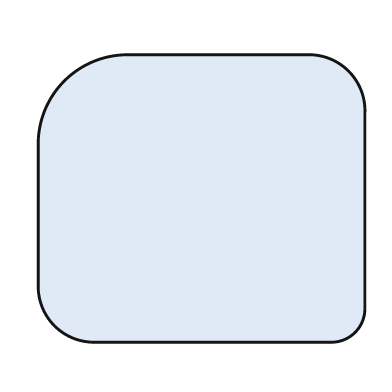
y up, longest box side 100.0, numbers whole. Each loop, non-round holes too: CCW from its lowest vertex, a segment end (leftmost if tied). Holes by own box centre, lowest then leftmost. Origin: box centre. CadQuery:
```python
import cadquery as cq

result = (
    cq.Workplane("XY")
    .moveTo(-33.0, -44.0)
    .lineTo(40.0, -44.0)
    .threePointArc((47.0, -41.0), (50.0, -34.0))
    .lineTo(50.0, 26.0)
    .threePointArc((45.0, 39.0), (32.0, 44.0))
    .lineTo(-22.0, 44.0)
    .threePointArc((-42.0, 36.0), (-50.0, 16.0))
    .lineTo(-50.0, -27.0)
    .threePointArc((-45.0, -39.0), (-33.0, -44.0))
    .close()
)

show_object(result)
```